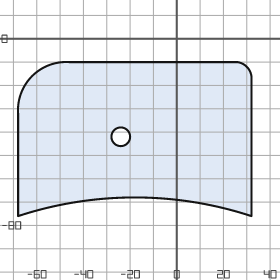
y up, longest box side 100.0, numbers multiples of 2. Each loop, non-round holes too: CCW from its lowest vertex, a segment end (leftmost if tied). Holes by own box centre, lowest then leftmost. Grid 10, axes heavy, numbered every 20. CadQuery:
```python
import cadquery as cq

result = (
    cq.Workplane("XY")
    .moveTo(-68.0, -76.0)
    .threePointArc((-18.0, -68.0), (32.0, -76.0))
    .lineTo(32.0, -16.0)
    .threePointArc((30.0, -12.0), (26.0, -10.0))
    .lineTo(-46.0, -10.0)
    .threePointArc((-62.0, -16.0), (-68.0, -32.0))
    .close()
    .moveTo(-24.0, -42.0)
    .circle(4.0)
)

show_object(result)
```